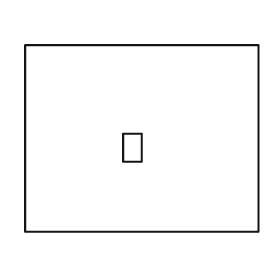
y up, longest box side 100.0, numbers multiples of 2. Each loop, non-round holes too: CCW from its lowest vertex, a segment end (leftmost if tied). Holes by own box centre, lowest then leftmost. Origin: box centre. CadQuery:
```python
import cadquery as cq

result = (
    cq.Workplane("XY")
    .moveTo(-50.0, -40.0)
    .lineTo(50.0, -40.0)
    .lineTo(50.0, 40.0)
    .lineTo(-50.0, 40.0)
    .close()
    .moveTo(-8.0, -10.0)
    .lineTo(0.0, -10.0)
    .lineTo(0.0, 2.0)
    .lineTo(-8.0, 2.0)
    .close()
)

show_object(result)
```